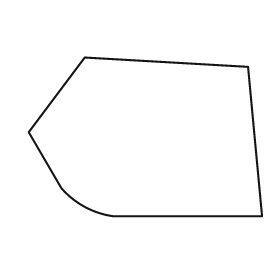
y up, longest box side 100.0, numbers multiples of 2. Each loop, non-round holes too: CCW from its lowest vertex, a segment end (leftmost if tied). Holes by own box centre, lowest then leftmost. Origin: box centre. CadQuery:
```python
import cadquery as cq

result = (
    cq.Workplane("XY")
    .moveTo(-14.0, -34.0)
    .lineTo(50.0, -34.0)
    .lineTo(44.0, 30.0)
    .lineTo(-26.0, 34.0)
    .lineTo(-50.0, 2.0)
    .lineTo(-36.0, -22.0)
    .threePointArc((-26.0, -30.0), (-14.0, -34.0))
    .close()
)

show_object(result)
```